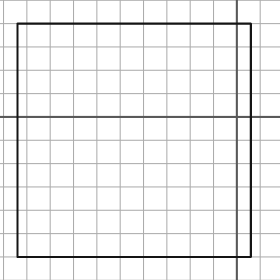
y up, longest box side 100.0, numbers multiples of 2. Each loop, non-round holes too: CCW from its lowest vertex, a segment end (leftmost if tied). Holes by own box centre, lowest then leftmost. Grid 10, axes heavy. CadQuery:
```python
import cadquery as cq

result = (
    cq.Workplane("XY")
    .moveTo(-94.0, -60.0)
    .lineTo(6.0, -60.0)
    .lineTo(6.0, 40.0)
    .lineTo(-94.0, 40.0)
    .close()
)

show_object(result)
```